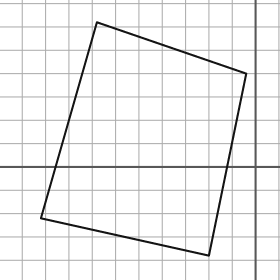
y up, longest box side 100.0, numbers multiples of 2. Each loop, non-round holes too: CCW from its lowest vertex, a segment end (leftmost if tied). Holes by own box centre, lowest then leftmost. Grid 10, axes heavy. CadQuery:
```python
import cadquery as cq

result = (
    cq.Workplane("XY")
    .moveTo(-20.0, -38.0)
    .lineTo(-4.0, 40.0)
    .lineTo(-68.0, 62.0)
    .lineTo(-92.0, -22.0)
    .close()
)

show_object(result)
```